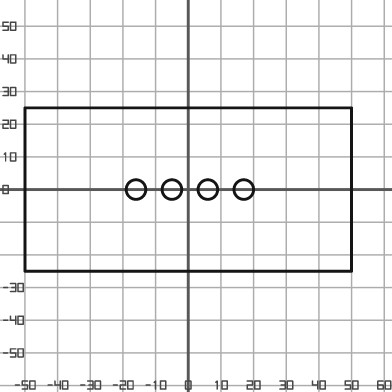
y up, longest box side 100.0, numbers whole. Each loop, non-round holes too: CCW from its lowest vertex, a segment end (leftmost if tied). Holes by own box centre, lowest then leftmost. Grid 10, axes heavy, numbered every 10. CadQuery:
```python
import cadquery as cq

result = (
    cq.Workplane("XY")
    .moveTo(-50.0, -25.0)
    .lineTo(50.0, -25.0)
    .lineTo(50.0, 25.0)
    .lineTo(-50.0, 25.0)
    .close()
    .moveTo(-16.0, 0.0)
    .circle(3.0)
    .moveTo(-5.0, 0.0)
    .circle(3.0)
    .moveTo(6.0, 0.0)
    .circle(3.0)
    .moveTo(17.0, 0.0)
    .circle(3.0)
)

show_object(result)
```